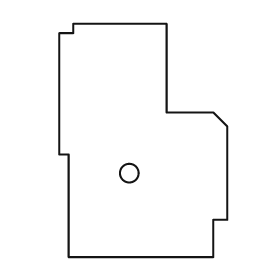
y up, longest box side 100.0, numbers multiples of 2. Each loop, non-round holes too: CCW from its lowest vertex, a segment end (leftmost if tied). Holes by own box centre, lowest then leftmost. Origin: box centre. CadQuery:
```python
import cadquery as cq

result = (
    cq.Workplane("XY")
    .moveTo(-32.0, -50.0)
    .lineTo(30.0, -50.0)
    .lineTo(30.0, -34.0)
    .lineTo(36.0, -34.0)
    .lineTo(36.0, 6.0)
    .lineTo(30.0, 12.0)
    .lineTo(10.0, 12.0)
    .lineTo(10.0, 50.0)
    .lineTo(-30.0, 50.0)
    .lineTo(-30.0, 46.0)
    .lineTo(-36.0, 46.0)
    .lineTo(-36.0, -6.0)
    .lineTo(-32.0, -6.0)
    .close()
    .moveTo(-6.0, -14.0)
    .circle(4.0)
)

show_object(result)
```